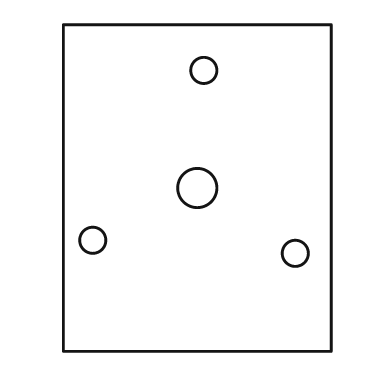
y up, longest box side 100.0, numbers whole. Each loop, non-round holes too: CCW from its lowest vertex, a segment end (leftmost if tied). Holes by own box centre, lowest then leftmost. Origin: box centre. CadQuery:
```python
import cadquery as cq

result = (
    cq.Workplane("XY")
    .moveTo(-41.0, -50.0)
    .lineTo(41.0, -50.0)
    .lineTo(41.0, 50.0)
    .lineTo(-41.0, 50.0)
    .close()
    .moveTo(30.0, -20.0)
    .circle(4.0)
    .moveTo(-32.0, -16.0)
    .circle(4.0)
    .moveTo(0.0, 0.0)
    .circle(6.0)
    .moveTo(2.0, 36.0)
    .circle(4.0)
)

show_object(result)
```